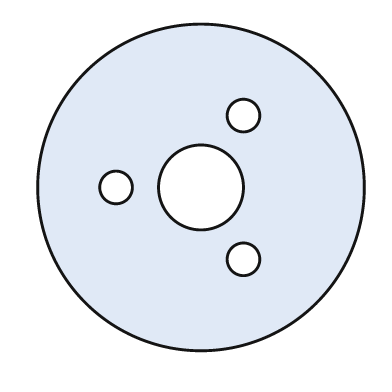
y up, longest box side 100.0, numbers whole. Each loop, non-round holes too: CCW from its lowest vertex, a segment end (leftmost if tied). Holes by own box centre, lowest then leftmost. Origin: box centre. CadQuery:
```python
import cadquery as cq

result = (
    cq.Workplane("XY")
    .moveTo(0.0, 0.0)
    .circle(50.0)
    .moveTo(13.0, -22.0)
    .circle(5.0)
    .moveTo(-26.0, 0.0)
    .circle(5.0)
    .moveTo(0.0, 0.0)
    .circle(13.0)
    .moveTo(13.0, 22.0)
    .circle(5.0)
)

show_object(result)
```